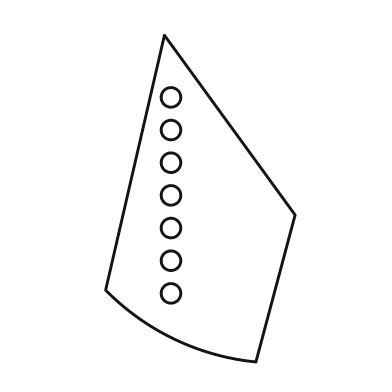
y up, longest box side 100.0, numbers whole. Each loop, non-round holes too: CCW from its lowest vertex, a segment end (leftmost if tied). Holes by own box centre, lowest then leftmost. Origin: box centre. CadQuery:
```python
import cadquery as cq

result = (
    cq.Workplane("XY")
    .moveTo(17.0, -50.0)
    .lineTo(29.0, -5.0)
    .lineTo(-11.0, 50.0)
    .lineTo(-29.0, -28.0)
    .threePointArc((-8.0, -43.0), (17.0, -50.0))
    .close()
    .moveTo(-9.0, -29.0)
    .circle(3.0)
    .moveTo(-9.0, -19.0)
    .circle(3.0)
    .moveTo(-9.0, -9.0)
    .circle(3.0)
    .moveTo(-9.0, 1.0)
    .circle(3.0)
    .moveTo(-9.0, 11.0)
    .circle(3.0)
    .moveTo(-9.0, 21.0)
    .circle(3.0)
    .moveTo(-9.0, 31.0)
    .circle(3.0)
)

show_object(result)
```